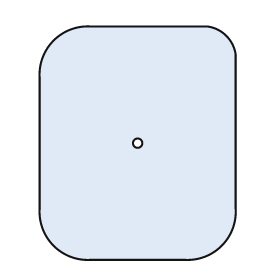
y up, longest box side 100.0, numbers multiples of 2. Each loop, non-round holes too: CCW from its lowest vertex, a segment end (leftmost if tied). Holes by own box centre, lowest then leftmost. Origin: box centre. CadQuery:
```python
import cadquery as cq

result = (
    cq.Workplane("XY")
    .moveTo(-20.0, -50.0)
    .lineTo(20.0, -50.0)
    .threePointArc((36.0, -44.0), (42.0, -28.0))
    .lineTo(42.0, 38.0)
    .threePointArc((38.0, 46.0), (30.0, 50.0))
    .lineTo(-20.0, 50.0)
    .threePointArc((-36.0, 44.0), (-42.0, 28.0))
    .lineTo(-42.0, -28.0)
    .threePointArc((-36.0, -44.0), (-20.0, -50.0))
    .close()
    .moveTo(0.0, 0.0)
    .circle(2.0)
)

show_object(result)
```